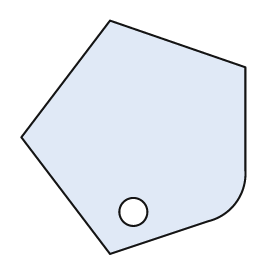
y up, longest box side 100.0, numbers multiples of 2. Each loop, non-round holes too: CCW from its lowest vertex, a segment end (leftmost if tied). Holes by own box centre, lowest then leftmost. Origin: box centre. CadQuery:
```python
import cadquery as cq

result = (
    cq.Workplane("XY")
    .moveTo(-10.0, -50.0)
    .lineTo(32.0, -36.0)
    .threePointArc((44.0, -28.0), (48.0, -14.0))
    .lineTo(48.0, 30.0)
    .lineTo(-10.0, 50.0)
    .lineTo(-48.0, 0.0)
    .close()
    .moveTo(0.0, -32.0)
    .circle(6.0)
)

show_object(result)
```